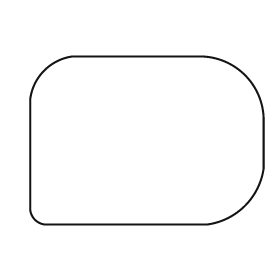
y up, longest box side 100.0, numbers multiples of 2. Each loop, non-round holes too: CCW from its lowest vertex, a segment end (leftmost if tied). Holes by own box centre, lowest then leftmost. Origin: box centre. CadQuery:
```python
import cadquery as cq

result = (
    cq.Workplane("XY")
    .moveTo(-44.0, -36.0)
    .lineTo(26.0, -36.0)
    .threePointArc((42.0, -28.0), (50.0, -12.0))
    .lineTo(50.0, 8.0)
    .threePointArc((42.0, 28.0), (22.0, 36.0))
    .lineTo(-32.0, 36.0)
    .threePointArc((-44.0, 30.0), (-50.0, 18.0))
    .lineTo(-50.0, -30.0)
    .threePointArc((-48.0, -34.0), (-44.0, -36.0))
    .close()
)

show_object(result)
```